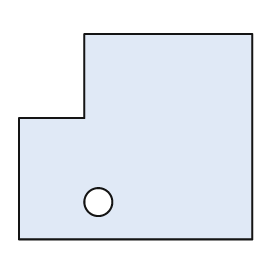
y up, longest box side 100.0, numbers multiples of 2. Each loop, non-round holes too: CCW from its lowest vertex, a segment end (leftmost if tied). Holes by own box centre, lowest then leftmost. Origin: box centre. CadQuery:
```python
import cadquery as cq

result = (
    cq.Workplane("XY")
    .moveTo(-50.0, -44.0)
    .lineTo(50.0, -44.0)
    .lineTo(50.0, 44.0)
    .lineTo(-22.0, 44.0)
    .lineTo(-22.0, 8.0)
    .lineTo(-50.0, 8.0)
    .close()
    .moveTo(-16.0, -28.0)
    .circle(6.0)
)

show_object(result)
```